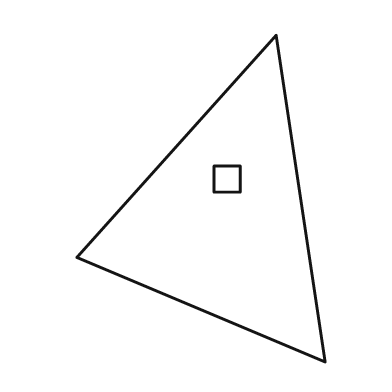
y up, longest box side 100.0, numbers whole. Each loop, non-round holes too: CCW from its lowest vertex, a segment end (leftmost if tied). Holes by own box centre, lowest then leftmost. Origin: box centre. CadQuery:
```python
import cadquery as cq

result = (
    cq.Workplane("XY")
    .moveTo(38.0, -50.0)
    .lineTo(23.0, 50.0)
    .lineTo(-38.0, -18.0)
    .close()
    .moveTo(4.0, 2.0)
    .lineTo(12.0, 2.0)
    .lineTo(12.0, 10.0)
    .lineTo(4.0, 10.0)
    .close()
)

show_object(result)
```